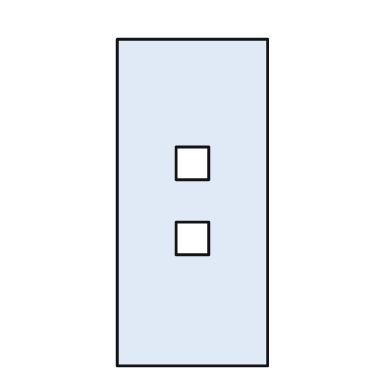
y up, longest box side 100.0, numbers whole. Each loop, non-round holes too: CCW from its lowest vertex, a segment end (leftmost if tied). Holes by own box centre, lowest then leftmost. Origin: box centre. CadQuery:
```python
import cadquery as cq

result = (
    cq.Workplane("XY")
    .moveTo(-23.0, -50.0)
    .lineTo(23.0, -50.0)
    .lineTo(23.0, 50.0)
    .lineTo(-23.0, 50.0)
    .close()
    .moveTo(-5.0, -16.0)
    .lineTo(5.0, -16.0)
    .lineTo(5.0, -6.0)
    .lineTo(-5.0, -6.0)
    .close()
    .moveTo(-5.0, 7.0)
    .lineTo(5.0, 7.0)
    .lineTo(5.0, 17.0)
    .lineTo(-5.0, 17.0)
    .close()
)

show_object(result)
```